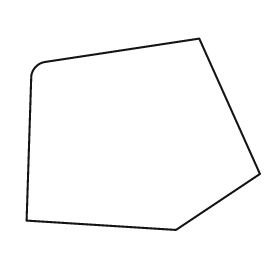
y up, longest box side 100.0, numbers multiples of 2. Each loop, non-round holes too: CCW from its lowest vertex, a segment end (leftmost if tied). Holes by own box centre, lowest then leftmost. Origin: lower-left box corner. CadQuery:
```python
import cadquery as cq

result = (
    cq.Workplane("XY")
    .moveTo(64.0, 0.0)
    .lineTo(100.0, 24.0)
    .lineTo(74.0, 82.0)
    .lineTo(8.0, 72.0)
    .threePointArc((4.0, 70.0), (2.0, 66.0))
    .lineTo(0.0, 4.0)
    .close()
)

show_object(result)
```